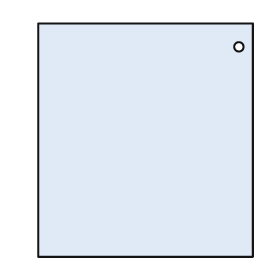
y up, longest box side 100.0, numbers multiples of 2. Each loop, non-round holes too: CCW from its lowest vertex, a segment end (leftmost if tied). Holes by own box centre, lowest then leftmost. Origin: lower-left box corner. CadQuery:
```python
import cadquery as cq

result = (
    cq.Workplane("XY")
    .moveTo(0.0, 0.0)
    .lineTo(92.0, 0.0)
    .lineTo(92.0, 100.0)
    .lineTo(0.0, 100.0)
    .close()
    .moveTo(86.0, 90.0)
    .circle(2.0)
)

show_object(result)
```